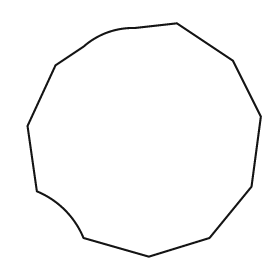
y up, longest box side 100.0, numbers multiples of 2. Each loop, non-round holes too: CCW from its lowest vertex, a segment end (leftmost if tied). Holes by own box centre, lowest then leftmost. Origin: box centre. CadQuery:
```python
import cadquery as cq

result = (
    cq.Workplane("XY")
    .moveTo(2.0, -50.0)
    .lineTo(28.0, -42.0)
    .lineTo(46.0, -20.0)
    .lineTo(50.0, 10.0)
    .lineTo(38.0, 34.0)
    .lineTo(14.0, 50.0)
    .lineTo(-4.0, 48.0)
    .threePointArc((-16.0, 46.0), (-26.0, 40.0))
    .lineTo(-38.0, 32.0)
    .lineTo(-50.0, 6.0)
    .lineTo(-46.0, -22.0)
    .threePointArc((-34.0, -30.0), (-26.0, -42.0))
    .close()
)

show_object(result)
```